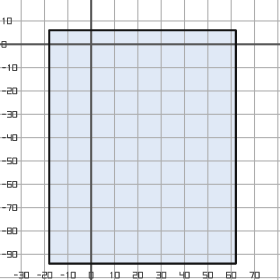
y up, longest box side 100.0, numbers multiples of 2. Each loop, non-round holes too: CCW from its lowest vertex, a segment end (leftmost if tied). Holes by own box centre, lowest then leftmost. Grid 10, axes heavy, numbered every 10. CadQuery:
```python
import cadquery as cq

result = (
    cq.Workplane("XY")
    .moveTo(-18.0, -94.0)
    .lineTo(62.0, -94.0)
    .lineTo(62.0, 6.0)
    .lineTo(-18.0, 6.0)
    .close()
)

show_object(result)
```